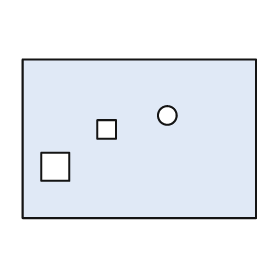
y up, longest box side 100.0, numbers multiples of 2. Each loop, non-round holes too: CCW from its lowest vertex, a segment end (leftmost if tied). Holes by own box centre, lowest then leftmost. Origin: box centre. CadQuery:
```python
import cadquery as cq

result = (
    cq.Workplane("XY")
    .moveTo(-50.0, -34.0)
    .lineTo(50.0, -34.0)
    .lineTo(50.0, 34.0)
    .lineTo(-50.0, 34.0)
    .close()
    .moveTo(-42.0, -18.0)
    .lineTo(-30.0, -18.0)
    .lineTo(-30.0, -6.0)
    .lineTo(-42.0, -6.0)
    .close()
    .moveTo(-18.0, 0.0)
    .lineTo(-10.0, 0.0)
    .lineTo(-10.0, 8.0)
    .lineTo(-18.0, 8.0)
    .close()
    .moveTo(12.0, 10.0)
    .circle(4.0)
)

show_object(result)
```